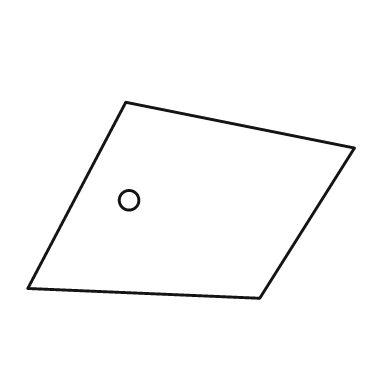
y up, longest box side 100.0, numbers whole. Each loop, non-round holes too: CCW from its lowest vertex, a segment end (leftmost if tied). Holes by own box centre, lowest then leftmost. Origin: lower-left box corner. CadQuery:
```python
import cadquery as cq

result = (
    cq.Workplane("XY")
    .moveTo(71.0, 0.0)
    .lineTo(100.0, 46.0)
    .lineTo(30.0, 60.0)
    .lineTo(0.0, 3.0)
    .close()
    .moveTo(31.0, 30.0)
    .circle(3.0)
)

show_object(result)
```